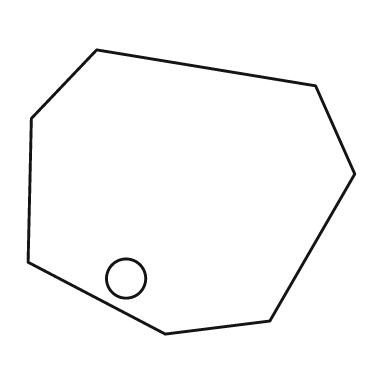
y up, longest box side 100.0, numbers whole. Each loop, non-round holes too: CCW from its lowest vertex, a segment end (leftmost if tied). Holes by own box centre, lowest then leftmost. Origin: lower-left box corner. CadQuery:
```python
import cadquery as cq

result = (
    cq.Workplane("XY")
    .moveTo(42.0, 0.0)
    .lineTo(74.0, 4.0)
    .lineTo(100.0, 49.0)
    .lineTo(88.0, 76.0)
    .lineTo(21.0, 87.0)
    .lineTo(1.0, 66.0)
    .lineTo(0.0, 22.0)
    .close()
    .moveTo(30.0, 17.0)
    .circle(6.0)
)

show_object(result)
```